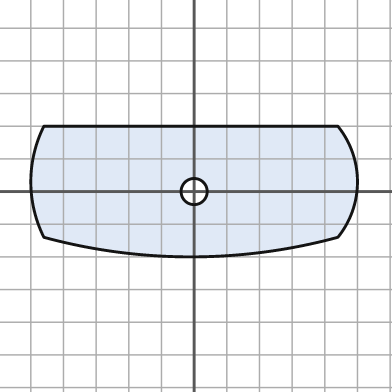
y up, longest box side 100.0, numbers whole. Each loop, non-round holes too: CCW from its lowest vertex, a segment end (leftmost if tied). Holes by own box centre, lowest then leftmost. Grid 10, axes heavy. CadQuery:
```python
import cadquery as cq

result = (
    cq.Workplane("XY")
    .moveTo(-46.0, -14.0)
    .threePointArc((-1.0, -20.0), (44.0, -14.0))
    .threePointArc((50.0, 3.0), (44.0, 20.0))
    .lineTo(-46.0, 20.0)
    .threePointArc((-50.0, 3.0), (-46.0, -14.0))
    .close()
    .moveTo(0.0, 0.0)
    .circle(4.0)
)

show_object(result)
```